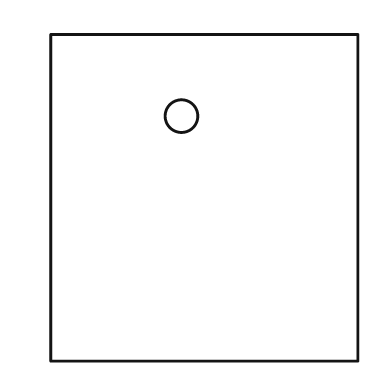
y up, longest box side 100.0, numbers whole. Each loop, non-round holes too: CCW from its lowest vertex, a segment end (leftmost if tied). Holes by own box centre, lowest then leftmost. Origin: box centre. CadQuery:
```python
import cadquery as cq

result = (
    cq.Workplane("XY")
    .moveTo(-47.0, -50.0)
    .lineTo(47.0, -50.0)
    .lineTo(47.0, 50.0)
    .lineTo(-47.0, 50.0)
    .close()
    .moveTo(-7.0, 25.0)
    .circle(5.0)
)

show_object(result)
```